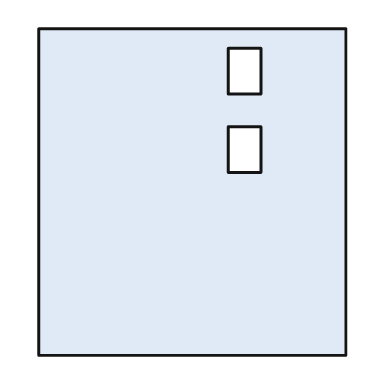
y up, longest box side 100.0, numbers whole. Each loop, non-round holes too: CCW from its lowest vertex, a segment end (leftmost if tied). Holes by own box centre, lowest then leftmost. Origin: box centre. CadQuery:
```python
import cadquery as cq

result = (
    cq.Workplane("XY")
    .moveTo(-47.0, -50.0)
    .lineTo(47.0, -50.0)
    .lineTo(47.0, 50.0)
    .lineTo(-47.0, 50.0)
    .close()
    .moveTo(11.0, 6.0)
    .lineTo(21.0, 6.0)
    .lineTo(21.0, 20.0)
    .lineTo(11.0, 20.0)
    .close()
    .moveTo(11.0, 30.0)
    .lineTo(21.0, 30.0)
    .lineTo(21.0, 44.0)
    .lineTo(11.0, 44.0)
    .close()
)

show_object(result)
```